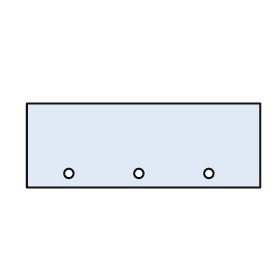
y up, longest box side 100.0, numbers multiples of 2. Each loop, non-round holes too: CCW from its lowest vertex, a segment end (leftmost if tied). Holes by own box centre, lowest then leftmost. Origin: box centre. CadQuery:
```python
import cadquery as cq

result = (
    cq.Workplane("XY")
    .moveTo(-50.0, -18.0)
    .lineTo(50.0, -18.0)
    .lineTo(50.0, 18.0)
    .lineTo(-50.0, 18.0)
    .close()
    .moveTo(-32.0, -12.0)
    .circle(2.0)
    .moveTo(-2.0, -12.0)
    .circle(2.0)
    .moveTo(28.0, -12.0)
    .circle(2.0)
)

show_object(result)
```